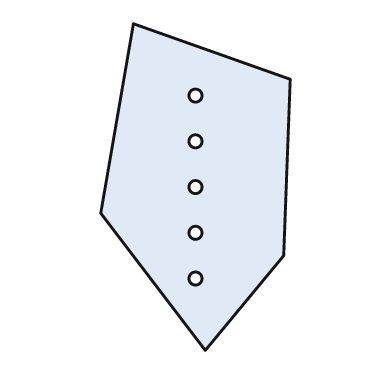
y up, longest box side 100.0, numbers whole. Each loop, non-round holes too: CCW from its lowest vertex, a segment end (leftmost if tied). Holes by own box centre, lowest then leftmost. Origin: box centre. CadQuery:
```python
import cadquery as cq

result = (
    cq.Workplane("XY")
    .moveTo(3.0, -50.0)
    .lineTo(27.0, -21.0)
    .lineTo(29.0, 33.0)
    .lineTo(-19.0, 50.0)
    .lineTo(-29.0, -8.0)
    .close()
    .moveTo(0.0, -28.0)
    .circle(2.0)
    .moveTo(0.0, -14.0)
    .circle(2.0)
    .moveTo(0.0, 0.0)
    .circle(2.0)
    .moveTo(0.0, 14.0)
    .circle(2.0)
    .moveTo(0.0, 28.0)
    .circle(2.0)
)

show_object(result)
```